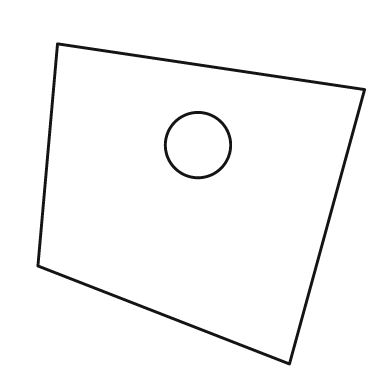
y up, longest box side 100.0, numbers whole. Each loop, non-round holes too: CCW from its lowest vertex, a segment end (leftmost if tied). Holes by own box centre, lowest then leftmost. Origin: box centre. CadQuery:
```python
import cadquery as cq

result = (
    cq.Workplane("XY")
    .moveTo(27.0, -49.0)
    .lineTo(50.0, 35.0)
    .lineTo(-44.0, 49.0)
    .lineTo(-50.0, -19.0)
    .close()
    .moveTo(-1.0, 18.0)
    .circle(10.0)
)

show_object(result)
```